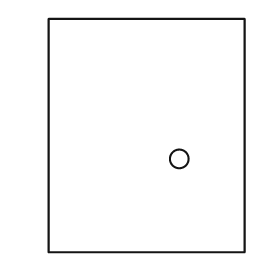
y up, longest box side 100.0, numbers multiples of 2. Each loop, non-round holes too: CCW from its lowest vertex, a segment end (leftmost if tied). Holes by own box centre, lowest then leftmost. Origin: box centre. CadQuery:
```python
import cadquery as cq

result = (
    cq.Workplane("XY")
    .moveTo(-42.0, -50.0)
    .lineTo(42.0, -50.0)
    .lineTo(42.0, 50.0)
    .lineTo(-42.0, 50.0)
    .close()
    .moveTo(14.0, -10.0)
    .circle(4.0)
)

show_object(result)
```